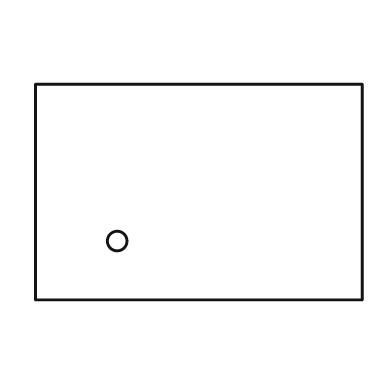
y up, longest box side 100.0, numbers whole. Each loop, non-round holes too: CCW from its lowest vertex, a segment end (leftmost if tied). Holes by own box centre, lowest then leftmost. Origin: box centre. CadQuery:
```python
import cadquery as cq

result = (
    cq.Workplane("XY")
    .moveTo(-50.0, -33.0)
    .lineTo(50.0, -33.0)
    .lineTo(50.0, 33.0)
    .lineTo(-50.0, 33.0)
    .close()
    .moveTo(-25.0, -15.0)
    .circle(3.0)
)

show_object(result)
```